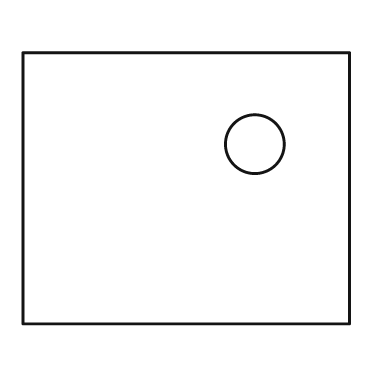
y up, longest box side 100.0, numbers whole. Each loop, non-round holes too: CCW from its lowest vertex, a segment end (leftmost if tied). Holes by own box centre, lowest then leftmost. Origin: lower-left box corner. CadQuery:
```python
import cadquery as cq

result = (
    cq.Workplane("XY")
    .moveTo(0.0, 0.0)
    .lineTo(100.0, 0.0)
    .lineTo(100.0, 83.0)
    .lineTo(0.0, 83.0)
    .close()
    .moveTo(71.0, 55.0)
    .circle(9.0)
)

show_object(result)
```